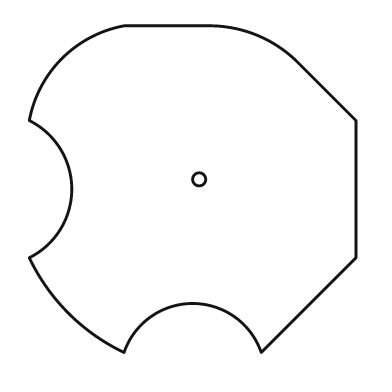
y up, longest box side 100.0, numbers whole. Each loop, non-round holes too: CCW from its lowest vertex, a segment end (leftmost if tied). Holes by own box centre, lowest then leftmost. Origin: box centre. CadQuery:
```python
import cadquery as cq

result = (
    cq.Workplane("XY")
    .moveTo(-21.0, -50.0)
    .threePointArc((0.0, -35.0), (21.0, -50.0))
    .lineTo(50.0, -21.0)
    .lineTo(50.0, 21.0)
    .lineTo(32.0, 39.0)
    .threePointArc((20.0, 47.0), (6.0, 50.0))
    .lineTo(-21.0, 50.0)
    .threePointArc((-40.0, 40.0), (-50.0, 21.0))
    .threePointArc((-37.0, 0.0), (-50.0, -21.0))
    .threePointArc((-38.0, -38.0), (-21.0, -50.0))
    .close()
    .moveTo(2.0, 3.0)
    .circle(2.0)
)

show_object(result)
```